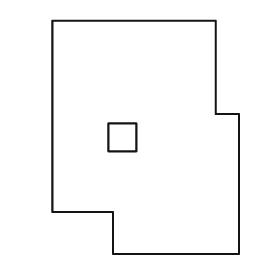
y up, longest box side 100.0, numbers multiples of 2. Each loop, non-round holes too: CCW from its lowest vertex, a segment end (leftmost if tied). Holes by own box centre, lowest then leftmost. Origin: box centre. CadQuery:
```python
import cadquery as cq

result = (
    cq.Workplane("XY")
    .moveTo(-14.0, -50.0)
    .lineTo(40.0, -50.0)
    .lineTo(40.0, 10.0)
    .lineTo(30.0, 10.0)
    .lineTo(30.0, 50.0)
    .lineTo(-40.0, 50.0)
    .lineTo(-40.0, -32.0)
    .lineTo(-14.0, -32.0)
    .close()
    .moveTo(-16.0, -6.0)
    .lineTo(-4.0, -6.0)
    .lineTo(-4.0, 6.0)
    .lineTo(-16.0, 6.0)
    .close()
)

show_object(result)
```